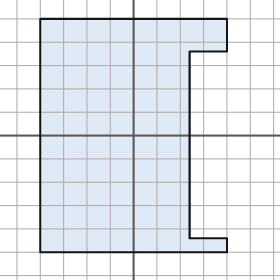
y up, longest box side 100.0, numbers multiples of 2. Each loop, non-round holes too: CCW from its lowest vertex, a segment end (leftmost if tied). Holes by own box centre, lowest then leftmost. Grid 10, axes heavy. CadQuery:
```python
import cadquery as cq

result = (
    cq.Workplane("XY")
    .moveTo(-40.0, -50.0)
    .lineTo(40.0, -50.0)
    .lineTo(40.0, -44.0)
    .lineTo(24.0, -44.0)
    .lineTo(24.0, 36.0)
    .lineTo(40.0, 36.0)
    .lineTo(40.0, 50.0)
    .lineTo(-40.0, 50.0)
    .close()
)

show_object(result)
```